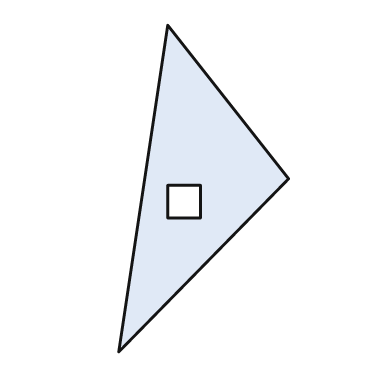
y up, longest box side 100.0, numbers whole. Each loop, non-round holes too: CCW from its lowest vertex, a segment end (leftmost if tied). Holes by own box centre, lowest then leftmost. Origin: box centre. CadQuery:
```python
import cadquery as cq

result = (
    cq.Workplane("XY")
    .moveTo(-26.0, -50.0)
    .lineTo(26.0, 3.0)
    .lineTo(-11.0, 50.0)
    .close()
    .moveTo(-11.0, -9.0)
    .lineTo(-1.0, -9.0)
    .lineTo(-1.0, 1.0)
    .lineTo(-11.0, 1.0)
    .close()
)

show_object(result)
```